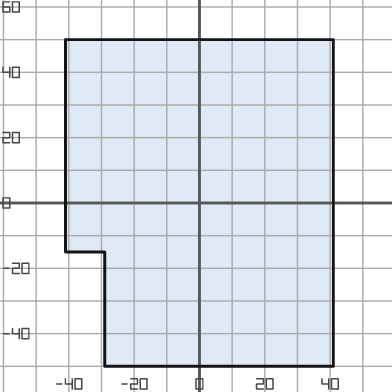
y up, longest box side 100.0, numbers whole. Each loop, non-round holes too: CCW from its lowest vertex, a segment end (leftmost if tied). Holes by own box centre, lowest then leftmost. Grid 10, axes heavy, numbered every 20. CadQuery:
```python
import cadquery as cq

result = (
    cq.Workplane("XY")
    .moveTo(-29.0, -50.0)
    .lineTo(41.0, -50.0)
    .lineTo(41.0, 50.0)
    .lineTo(-41.0, 50.0)
    .lineTo(-41.0, -15.0)
    .lineTo(-29.0, -15.0)
    .close()
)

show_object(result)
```